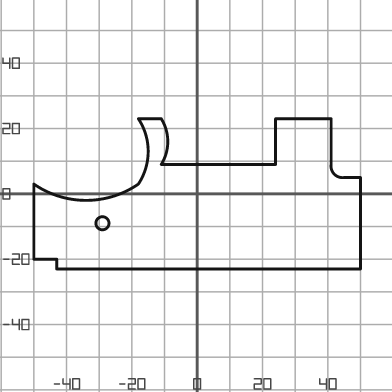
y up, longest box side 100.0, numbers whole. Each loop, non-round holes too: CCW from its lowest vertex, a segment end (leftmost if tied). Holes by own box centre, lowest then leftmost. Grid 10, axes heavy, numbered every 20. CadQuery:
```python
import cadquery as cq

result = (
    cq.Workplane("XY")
    .moveTo(-43.0, -23.0)
    .lineTo(50.0, -23.0)
    .lineTo(50.0, 5.0)
    .lineTo(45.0, 5.0)
    .threePointArc((42.0, 6.0), (41.0, 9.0))
    .lineTo(41.0, 23.0)
    .lineTo(24.0, 23.0)
    .lineTo(24.0, 9.0)
    .lineTo(-11.0, 9.0)
    .threePointArc((-9.0, 16.0), (-11.0, 23.0))
    .lineTo(-18.0, 23.0)
    .threePointArc((-15.0, 13.0), (-18.0, 3.0))
    .threePointArc((-34.0, -2.0), (-50.0, 3.0))
    .lineTo(-50.0, -20.0)
    .lineTo(-43.0, -20.0)
    .close()
    .moveTo(-29.0, -9.0)
    .circle(2.0)
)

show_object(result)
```